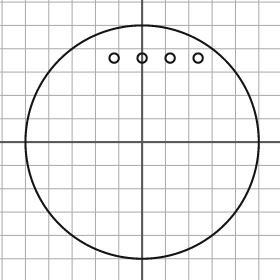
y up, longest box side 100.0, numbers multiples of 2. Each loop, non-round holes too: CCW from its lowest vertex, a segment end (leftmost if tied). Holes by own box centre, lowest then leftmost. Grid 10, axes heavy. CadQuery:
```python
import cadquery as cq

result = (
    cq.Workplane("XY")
    .moveTo(0.0, 0.0)
    .circle(50.0)
    .moveTo(-12.0, 36.0)
    .circle(2.0)
    .moveTo(0.0, 36.0)
    .circle(2.0)
    .moveTo(12.0, 36.0)
    .circle(2.0)
    .moveTo(24.0, 36.0)
    .circle(2.0)
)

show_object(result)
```